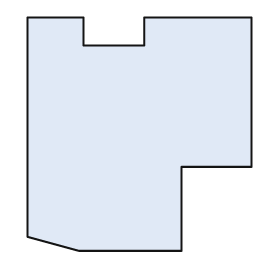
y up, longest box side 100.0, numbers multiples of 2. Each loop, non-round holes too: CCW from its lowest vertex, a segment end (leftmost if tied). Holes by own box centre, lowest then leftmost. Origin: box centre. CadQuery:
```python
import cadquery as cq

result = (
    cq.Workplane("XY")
    .moveTo(-26.0, -50.0)
    .lineTo(18.0, -50.0)
    .lineTo(18.0, -14.0)
    .lineTo(48.0, -14.0)
    .lineTo(48.0, 50.0)
    .lineTo(2.0, 50.0)
    .lineTo(2.0, 38.0)
    .lineTo(-24.0, 38.0)
    .lineTo(-24.0, 50.0)
    .lineTo(-48.0, 50.0)
    .lineTo(-48.0, -44.0)
    .close()
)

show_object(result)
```